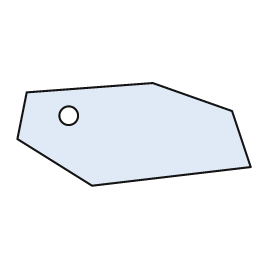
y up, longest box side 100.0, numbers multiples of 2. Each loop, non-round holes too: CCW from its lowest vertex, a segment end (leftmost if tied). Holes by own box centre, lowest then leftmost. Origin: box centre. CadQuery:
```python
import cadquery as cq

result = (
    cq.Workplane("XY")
    .moveTo(-18.0, -22.0)
    .lineTo(50.0, -14.0)
    .lineTo(42.0, 10.0)
    .lineTo(8.0, 22.0)
    .lineTo(-46.0, 18.0)
    .lineTo(-50.0, -2.0)
    .close()
    .moveTo(-28.0, 8.0)
    .circle(4.0)
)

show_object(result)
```